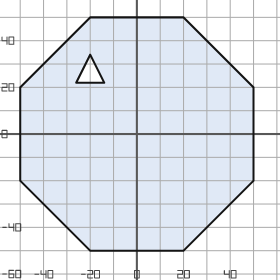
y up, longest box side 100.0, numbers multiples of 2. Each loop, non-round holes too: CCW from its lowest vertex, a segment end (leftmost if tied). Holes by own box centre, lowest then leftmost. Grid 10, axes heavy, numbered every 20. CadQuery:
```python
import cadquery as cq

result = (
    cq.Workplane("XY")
    .moveTo(-20.0, -50.0)
    .lineTo(20.0, -50.0)
    .lineTo(50.0, -20.0)
    .lineTo(50.0, 20.0)
    .lineTo(20.0, 50.0)
    .lineTo(-20.0, 50.0)
    .lineTo(-50.0, 20.0)
    .lineTo(-50.0, -20.0)
    .close()
    .moveTo(-26.0, 22.0)
    .lineTo(-14.0, 22.0)
    .lineTo(-20.0, 34.0)
    .close()
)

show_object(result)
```